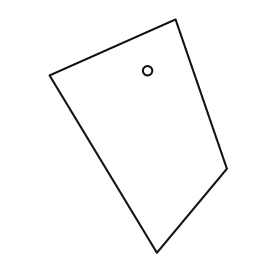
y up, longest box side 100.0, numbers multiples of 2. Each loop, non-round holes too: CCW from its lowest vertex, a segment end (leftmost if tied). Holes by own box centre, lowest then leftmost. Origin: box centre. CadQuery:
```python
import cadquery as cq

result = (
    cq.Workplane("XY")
    .moveTo(8.0, -50.0)
    .lineTo(38.0, -14.0)
    .lineTo(16.0, 50.0)
    .lineTo(-38.0, 26.0)
    .close()
    .moveTo(4.0, 28.0)
    .circle(2.0)
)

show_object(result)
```